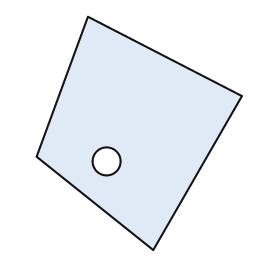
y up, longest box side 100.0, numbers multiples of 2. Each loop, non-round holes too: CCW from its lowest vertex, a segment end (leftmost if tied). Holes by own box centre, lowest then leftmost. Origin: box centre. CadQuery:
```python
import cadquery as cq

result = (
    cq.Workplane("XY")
    .moveTo(6.0, -50.0)
    .lineTo(44.0, 16.0)
    .lineTo(-22.0, 50.0)
    .lineTo(-44.0, -10.0)
    .close()
    .moveTo(-14.0, -12.0)
    .circle(6.0)
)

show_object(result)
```